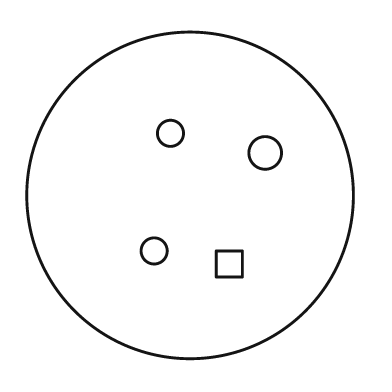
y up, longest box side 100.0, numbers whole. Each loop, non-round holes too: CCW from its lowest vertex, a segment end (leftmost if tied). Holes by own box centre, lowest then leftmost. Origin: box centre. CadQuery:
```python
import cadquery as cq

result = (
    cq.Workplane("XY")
    .moveTo(0.0, 0.0)
    .circle(50.0)
    .moveTo(8.0, -25.0)
    .lineTo(16.0, -25.0)
    .lineTo(16.0, -17.0)
    .lineTo(8.0, -17.0)
    .close()
    .moveTo(-11.0, -17.0)
    .circle(4.0)
    .moveTo(23.0, 13.0)
    .circle(5.0)
    .moveTo(-6.0, 19.0)
    .circle(4.0)
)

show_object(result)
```